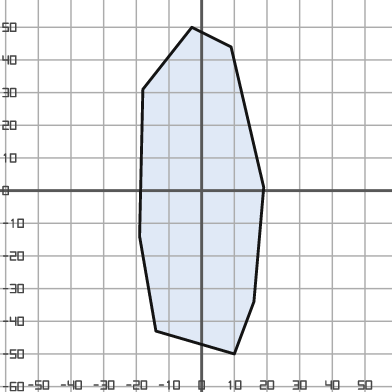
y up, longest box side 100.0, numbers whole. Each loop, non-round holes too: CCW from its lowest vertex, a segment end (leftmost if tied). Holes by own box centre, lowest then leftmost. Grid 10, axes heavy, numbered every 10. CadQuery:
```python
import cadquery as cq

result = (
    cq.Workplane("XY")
    .moveTo(10.0, -50.0)
    .lineTo(16.0, -34.0)
    .lineTo(19.0, 1.0)
    .lineTo(9.0, 44.0)
    .lineTo(-3.0, 50.0)
    .lineTo(-18.0, 31.0)
    .lineTo(-19.0, -14.0)
    .lineTo(-14.0, -43.0)
    .close()
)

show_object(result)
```